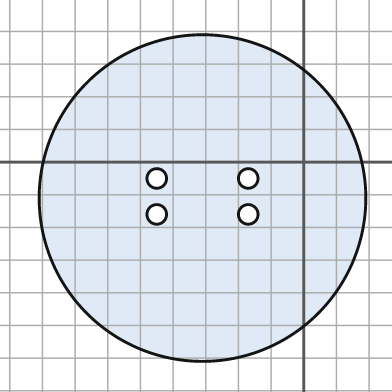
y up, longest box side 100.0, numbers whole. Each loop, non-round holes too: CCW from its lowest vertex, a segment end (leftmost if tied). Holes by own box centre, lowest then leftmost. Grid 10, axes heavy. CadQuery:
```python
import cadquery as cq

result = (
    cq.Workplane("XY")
    .moveTo(-31.0, -11.0)
    .circle(50.0)
    .moveTo(-45.0, -16.0)
    .circle(3.0)
    .moveTo(-17.0, -16.0)
    .circle(3.0)
    .moveTo(-45.0, -5.0)
    .circle(3.0)
    .moveTo(-17.0, -5.0)
    .circle(3.0)
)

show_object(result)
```